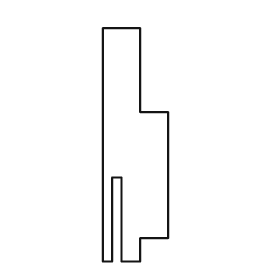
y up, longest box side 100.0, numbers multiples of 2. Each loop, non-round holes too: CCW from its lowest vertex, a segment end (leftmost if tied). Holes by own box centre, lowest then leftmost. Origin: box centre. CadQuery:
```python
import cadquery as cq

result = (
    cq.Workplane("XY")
    .moveTo(-14.0, -50.0)
    .lineTo(-10.0, -50.0)
    .lineTo(-10.0, -14.0)
    .lineTo(-6.0, -14.0)
    .lineTo(-6.0, -50.0)
    .lineTo(2.0, -50.0)
    .lineTo(2.0, -40.0)
    .lineTo(14.0, -40.0)
    .lineTo(14.0, 14.0)
    .lineTo(2.0, 14.0)
    .lineTo(2.0, 50.0)
    .lineTo(-14.0, 50.0)
    .close()
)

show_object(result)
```